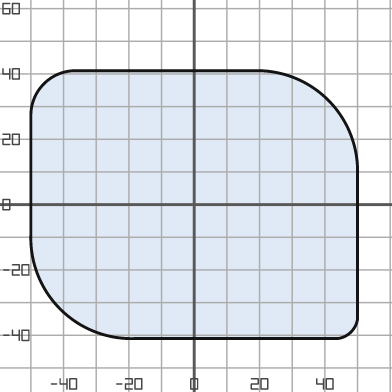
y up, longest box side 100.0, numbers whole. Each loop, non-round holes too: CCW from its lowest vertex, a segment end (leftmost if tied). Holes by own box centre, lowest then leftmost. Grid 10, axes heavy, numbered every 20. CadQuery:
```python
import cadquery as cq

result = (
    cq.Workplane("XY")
    .moveTo(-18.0, -41.0)
    .lineTo(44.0, -41.0)
    .threePointArc((48.0, -39.0), (50.0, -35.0))
    .lineTo(50.0, 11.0)
    .threePointArc((41.0, 32.0), (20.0, 41.0))
    .lineTo(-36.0, 41.0)
    .threePointArc((-46.0, 37.0), (-50.0, 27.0))
    .lineTo(-50.0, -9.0)
    .threePointArc((-41.0, -32.0), (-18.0, -41.0))
    .close()
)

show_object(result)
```